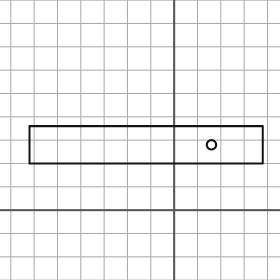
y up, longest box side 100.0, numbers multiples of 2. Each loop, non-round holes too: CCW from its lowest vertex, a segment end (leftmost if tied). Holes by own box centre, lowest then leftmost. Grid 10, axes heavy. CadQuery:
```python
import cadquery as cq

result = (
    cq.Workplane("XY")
    .moveTo(-62.0, 20.0)
    .lineTo(38.0, 20.0)
    .lineTo(38.0, 36.0)
    .lineTo(-62.0, 36.0)
    .close()
    .moveTo(16.0, 28.0)
    .circle(2.0)
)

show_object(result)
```